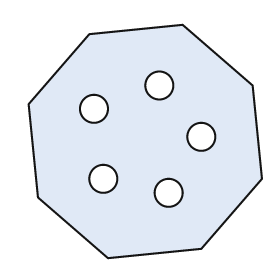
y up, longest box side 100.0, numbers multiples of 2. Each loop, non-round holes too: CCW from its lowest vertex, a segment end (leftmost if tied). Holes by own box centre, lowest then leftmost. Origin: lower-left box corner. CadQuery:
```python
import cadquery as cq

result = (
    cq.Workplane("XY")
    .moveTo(34.0, 0.0)
    .lineTo(74.0, 4.0)
    .lineTo(100.0, 34.0)
    .lineTo(96.0, 74.0)
    .lineTo(66.0, 100.0)
    .lineTo(26.0, 96.0)
    .lineTo(0.0, 66.0)
    .lineTo(4.0, 26.0)
    .close()
    .moveTo(60.0, 28.0)
    .circle(6.0)
    .moveTo(32.0, 34.0)
    .circle(6.0)
    .moveTo(74.0, 52.0)
    .circle(6.0)
    .moveTo(28.0, 64.0)
    .circle(6.0)
    .moveTo(56.0, 74.0)
    .circle(6.0)
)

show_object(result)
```